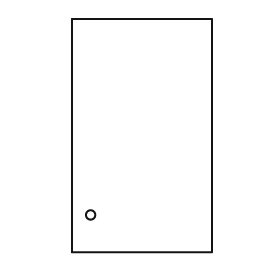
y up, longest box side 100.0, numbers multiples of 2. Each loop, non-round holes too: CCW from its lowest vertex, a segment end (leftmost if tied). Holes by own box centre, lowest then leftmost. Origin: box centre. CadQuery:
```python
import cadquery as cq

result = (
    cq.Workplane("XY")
    .moveTo(-30.0, -50.0)
    .lineTo(30.0, -50.0)
    .lineTo(30.0, 50.0)
    .lineTo(-30.0, 50.0)
    .close()
    .moveTo(-22.0, -34.0)
    .circle(2.0)
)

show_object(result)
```